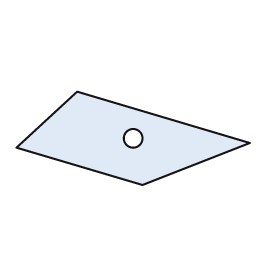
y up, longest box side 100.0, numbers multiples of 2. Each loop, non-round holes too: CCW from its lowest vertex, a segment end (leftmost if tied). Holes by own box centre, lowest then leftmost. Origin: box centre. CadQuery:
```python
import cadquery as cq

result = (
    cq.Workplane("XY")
    .moveTo(4.0, -20.0)
    .lineTo(50.0, -2.0)
    .lineTo(-24.0, 20.0)
    .lineTo(-50.0, -4.0)
    .close()
    .moveTo(0.0, 0.0)
    .circle(4.0)
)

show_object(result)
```